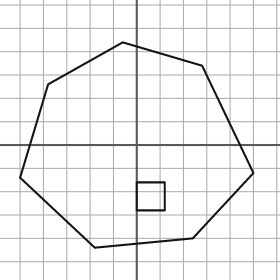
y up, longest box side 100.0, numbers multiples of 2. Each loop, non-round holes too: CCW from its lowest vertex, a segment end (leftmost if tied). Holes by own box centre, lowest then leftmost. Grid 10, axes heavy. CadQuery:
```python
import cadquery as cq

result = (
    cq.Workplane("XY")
    .moveTo(-18.0, -44.0)
    .lineTo(24.0, -40.0)
    .lineTo(50.0, -12.0)
    .lineTo(28.0, 34.0)
    .lineTo(-6.0, 44.0)
    .lineTo(-38.0, 26.0)
    .lineTo(-50.0, -14.0)
    .close()
    .moveTo(0.0, -28.0)
    .lineTo(12.0, -28.0)
    .lineTo(12.0, -16.0)
    .lineTo(0.0, -16.0)
    .close()
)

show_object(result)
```